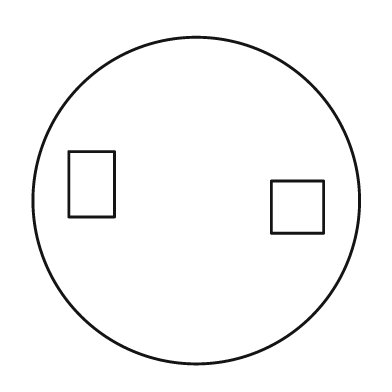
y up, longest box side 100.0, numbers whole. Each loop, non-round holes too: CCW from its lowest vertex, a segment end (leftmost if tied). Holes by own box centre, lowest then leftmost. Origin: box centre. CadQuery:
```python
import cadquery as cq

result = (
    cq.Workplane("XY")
    .moveTo(0.0, 0.0)
    .circle(50.0)
    .moveTo(23.0, -10.0)
    .lineTo(39.0, -10.0)
    .lineTo(39.0, 6.0)
    .lineTo(23.0, 6.0)
    .close()
    .moveTo(-39.0, -5.0)
    .lineTo(-25.0, -5.0)
    .lineTo(-25.0, 15.0)
    .lineTo(-39.0, 15.0)
    .close()
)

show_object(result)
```